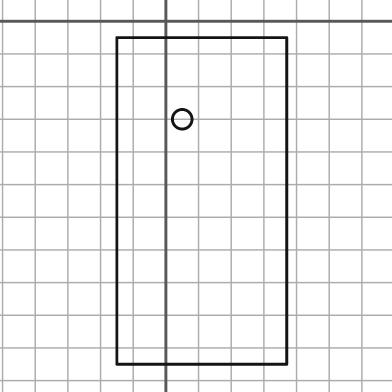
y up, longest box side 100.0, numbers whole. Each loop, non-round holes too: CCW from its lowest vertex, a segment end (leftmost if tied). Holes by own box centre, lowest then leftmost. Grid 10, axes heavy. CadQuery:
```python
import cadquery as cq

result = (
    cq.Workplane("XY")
    .moveTo(-15.0, -105.0)
    .lineTo(37.0, -105.0)
    .lineTo(37.0, -5.0)
    .lineTo(-15.0, -5.0)
    .close()
    .moveTo(5.0, -30.0)
    .circle(3.0)
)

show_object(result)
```